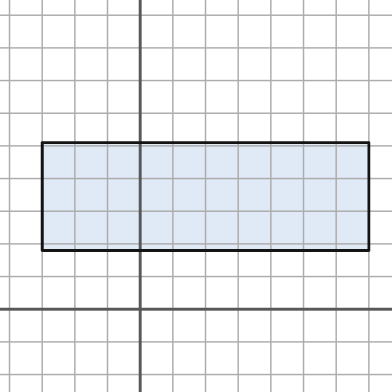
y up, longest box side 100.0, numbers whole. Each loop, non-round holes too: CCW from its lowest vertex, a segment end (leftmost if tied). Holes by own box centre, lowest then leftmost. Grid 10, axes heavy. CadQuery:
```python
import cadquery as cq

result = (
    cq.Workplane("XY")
    .moveTo(-30.0, 18.0)
    .lineTo(70.0, 18.0)
    .lineTo(70.0, 51.0)
    .lineTo(-30.0, 51.0)
    .close()
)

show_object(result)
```